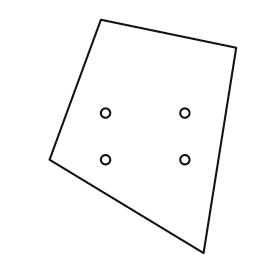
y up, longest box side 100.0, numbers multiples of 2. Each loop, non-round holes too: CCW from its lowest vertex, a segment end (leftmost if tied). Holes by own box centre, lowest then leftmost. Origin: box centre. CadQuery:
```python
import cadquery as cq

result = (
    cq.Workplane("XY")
    .moveTo(26.0, -50.0)
    .lineTo(40.0, 38.0)
    .lineTo(-18.0, 50.0)
    .lineTo(-40.0, -10.0)
    .close()
    .moveTo(-16.0, -10.0)
    .circle(2.0)
    .moveTo(18.0, -10.0)
    .circle(2.0)
    .moveTo(-16.0, 10.0)
    .circle(2.0)
    .moveTo(18.0, 10.0)
    .circle(2.0)
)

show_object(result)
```